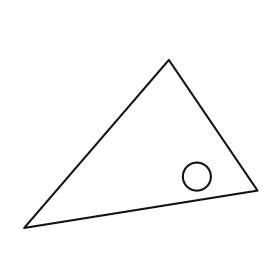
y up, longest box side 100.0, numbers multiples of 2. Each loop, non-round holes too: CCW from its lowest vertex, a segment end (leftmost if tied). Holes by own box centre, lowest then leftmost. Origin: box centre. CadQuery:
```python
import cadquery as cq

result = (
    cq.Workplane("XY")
    .moveTo(-50.0, -36.0)
    .lineTo(50.0, -20.0)
    .lineTo(12.0, 36.0)
    .close()
    .moveTo(24.0, -14.0)
    .circle(6.0)
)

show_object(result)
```